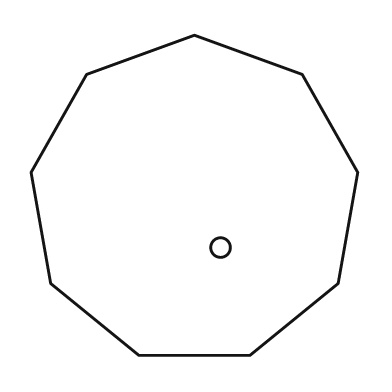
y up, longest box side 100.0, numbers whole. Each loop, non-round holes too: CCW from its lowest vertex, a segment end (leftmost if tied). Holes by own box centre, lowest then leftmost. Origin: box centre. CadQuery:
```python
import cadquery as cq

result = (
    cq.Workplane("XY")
    .moveTo(-17.0, -49.0)
    .lineTo(17.0, -49.0)
    .lineTo(44.0, -27.0)
    .lineTo(50.0, 7.0)
    .lineTo(33.0, 37.0)
    .lineTo(0.0, 49.0)
    .lineTo(-33.0, 37.0)
    .lineTo(-50.0, 7.0)
    .lineTo(-44.0, -27.0)
    .close()
    .moveTo(8.0, -16.0)
    .circle(3.0)
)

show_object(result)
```